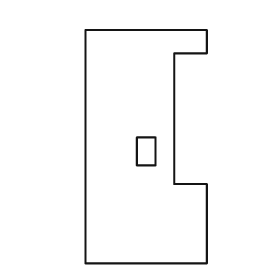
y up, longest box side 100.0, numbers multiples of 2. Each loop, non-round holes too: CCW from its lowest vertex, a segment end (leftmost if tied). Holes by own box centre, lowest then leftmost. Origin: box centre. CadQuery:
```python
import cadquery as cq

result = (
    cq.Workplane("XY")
    .moveTo(-26.0, -50.0)
    .lineTo(26.0, -50.0)
    .lineTo(26.0, -16.0)
    .lineTo(12.0, -16.0)
    .lineTo(12.0, 40.0)
    .lineTo(26.0, 40.0)
    .lineTo(26.0, 50.0)
    .lineTo(-26.0, 50.0)
    .close()
    .moveTo(-4.0, -8.0)
    .lineTo(4.0, -8.0)
    .lineTo(4.0, 4.0)
    .lineTo(-4.0, 4.0)
    .close()
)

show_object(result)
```